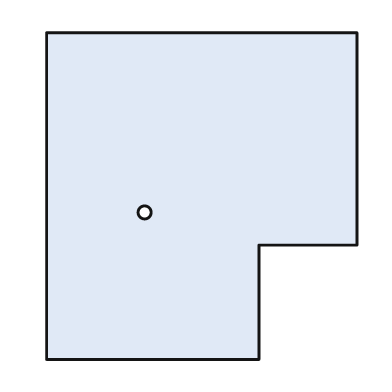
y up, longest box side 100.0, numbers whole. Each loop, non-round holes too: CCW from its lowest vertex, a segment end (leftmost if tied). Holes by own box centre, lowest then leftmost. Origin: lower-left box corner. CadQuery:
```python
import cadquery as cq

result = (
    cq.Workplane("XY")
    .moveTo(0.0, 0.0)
    .lineTo(65.0, 0.0)
    .lineTo(65.0, 35.0)
    .lineTo(95.0, 35.0)
    .lineTo(95.0, 100.0)
    .lineTo(0.0, 100.0)
    .close()
    .moveTo(30.0, 45.0)
    .circle(2.0)
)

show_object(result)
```